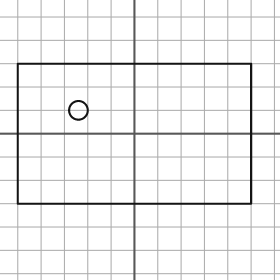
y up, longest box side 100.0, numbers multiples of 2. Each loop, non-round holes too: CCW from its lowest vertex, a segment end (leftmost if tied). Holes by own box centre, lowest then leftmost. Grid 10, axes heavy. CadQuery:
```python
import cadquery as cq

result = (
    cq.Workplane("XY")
    .moveTo(-50.0, -30.0)
    .lineTo(50.0, -30.0)
    .lineTo(50.0, 30.0)
    .lineTo(-50.0, 30.0)
    .close()
    .moveTo(-24.0, 10.0)
    .circle(4.0)
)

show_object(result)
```